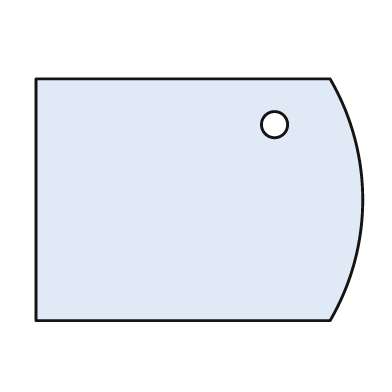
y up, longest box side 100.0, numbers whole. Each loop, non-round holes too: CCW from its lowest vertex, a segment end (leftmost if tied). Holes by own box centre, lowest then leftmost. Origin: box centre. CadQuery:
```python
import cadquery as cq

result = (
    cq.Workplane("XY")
    .moveTo(-50.0, -37.0)
    .lineTo(40.0, -37.0)
    .threePointArc((50.0, 0.0), (40.0, 37.0))
    .lineTo(-50.0, 37.0)
    .close()
    .moveTo(23.0, 23.0)
    .circle(4.0)
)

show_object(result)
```